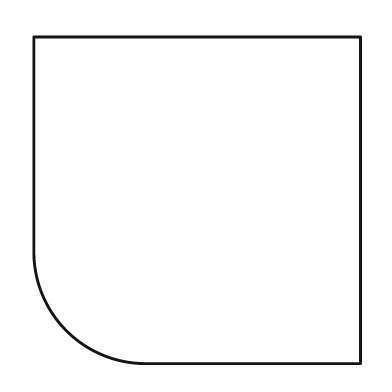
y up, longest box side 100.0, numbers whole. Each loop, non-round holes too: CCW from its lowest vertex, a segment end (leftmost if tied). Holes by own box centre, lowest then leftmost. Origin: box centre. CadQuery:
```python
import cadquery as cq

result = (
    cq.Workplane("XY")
    .moveTo(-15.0, -50.0)
    .lineTo(50.0, -50.0)
    .lineTo(50.0, 50.0)
    .lineTo(-50.0, 50.0)
    .lineTo(-50.0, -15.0)
    .threePointArc((-40.0, -40.0), (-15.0, -50.0))
    .close()
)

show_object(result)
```